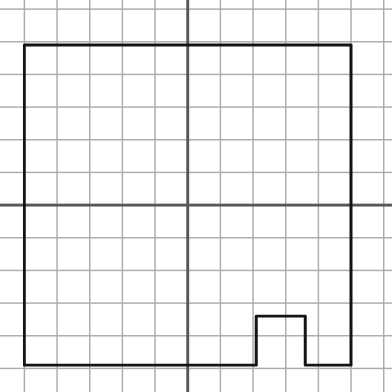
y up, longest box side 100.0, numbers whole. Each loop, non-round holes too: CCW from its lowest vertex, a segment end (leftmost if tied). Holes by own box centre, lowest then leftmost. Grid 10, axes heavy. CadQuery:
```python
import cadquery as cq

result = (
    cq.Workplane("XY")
    .moveTo(-50.0, -49.0)
    .lineTo(21.0, -49.0)
    .lineTo(21.0, -34.0)
    .lineTo(36.0, -34.0)
    .lineTo(36.0, -49.0)
    .lineTo(50.0, -49.0)
    .lineTo(50.0, 49.0)
    .lineTo(-50.0, 49.0)
    .close()
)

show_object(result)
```